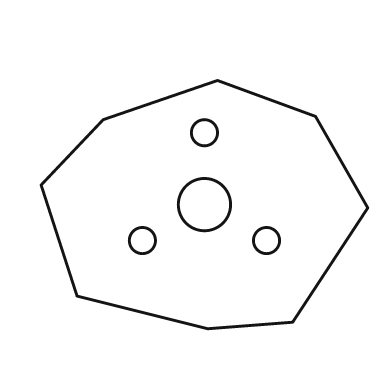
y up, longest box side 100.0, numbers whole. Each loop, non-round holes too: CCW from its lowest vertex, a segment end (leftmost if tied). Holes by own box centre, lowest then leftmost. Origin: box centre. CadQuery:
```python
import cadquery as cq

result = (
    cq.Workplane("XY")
    .moveTo(1.0, -38.0)
    .lineTo(27.0, -36.0)
    .lineTo(50.0, -1.0)
    .lineTo(34.0, 27.0)
    .lineTo(4.0, 38.0)
    .lineTo(-31.0, 26.0)
    .lineTo(-50.0, 6.0)
    .lineTo(-39.0, -28.0)
    .close()
    .moveTo(-19.0, -11.0)
    .circle(4.0)
    .moveTo(19.0, -11.0)
    .circle(4.0)
    .moveTo(0.0, 0.0)
    .circle(8.0)
    .moveTo(0.0, 22.0)
    .circle(4.0)
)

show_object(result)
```